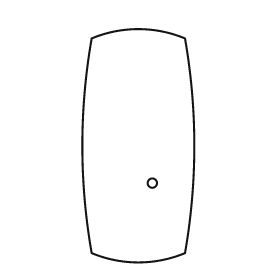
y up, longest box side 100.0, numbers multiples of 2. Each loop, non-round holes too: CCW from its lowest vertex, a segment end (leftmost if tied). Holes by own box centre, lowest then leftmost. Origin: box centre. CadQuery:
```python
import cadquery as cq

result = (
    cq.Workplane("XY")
    .moveTo(-20.0, -46.0)
    .threePointArc((0.0, -50.0), (20.0, -46.0))
    .threePointArc((24.0, 0.0), (20.0, 46.0))
    .threePointArc((0.0, 50.0), (-20.0, 46.0))
    .threePointArc((-24.0, 0.0), (-20.0, -46.0))
    .close()
    .moveTo(6.0, -16.0)
    .circle(2.0)
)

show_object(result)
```